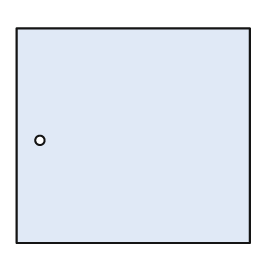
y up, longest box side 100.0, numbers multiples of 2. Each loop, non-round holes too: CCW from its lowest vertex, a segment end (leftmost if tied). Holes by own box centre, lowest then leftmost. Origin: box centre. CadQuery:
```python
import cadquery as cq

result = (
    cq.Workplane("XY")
    .moveTo(-50.0, -46.0)
    .lineTo(50.0, -46.0)
    .lineTo(50.0, 46.0)
    .lineTo(-50.0, 46.0)
    .close()
    .moveTo(-40.0, -2.0)
    .circle(2.0)
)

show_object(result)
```